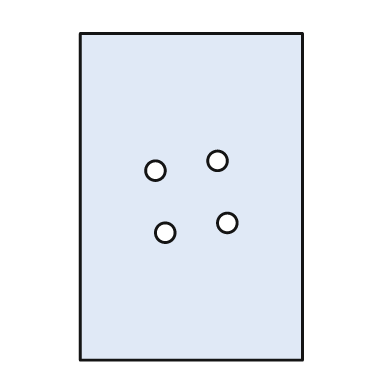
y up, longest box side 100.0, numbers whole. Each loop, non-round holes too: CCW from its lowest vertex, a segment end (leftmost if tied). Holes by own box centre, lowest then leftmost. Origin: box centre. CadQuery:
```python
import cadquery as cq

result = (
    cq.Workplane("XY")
    .moveTo(-34.0, -50.0)
    .lineTo(34.0, -50.0)
    .lineTo(34.0, 50.0)
    .lineTo(-34.0, 50.0)
    .close()
    .moveTo(-8.0, -11.0)
    .circle(3.0)
    .moveTo(11.0, -8.0)
    .circle(3.0)
    .moveTo(-11.0, 8.0)
    .circle(3.0)
    .moveTo(8.0, 11.0)
    .circle(3.0)
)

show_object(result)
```